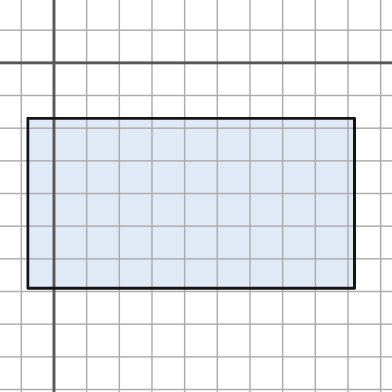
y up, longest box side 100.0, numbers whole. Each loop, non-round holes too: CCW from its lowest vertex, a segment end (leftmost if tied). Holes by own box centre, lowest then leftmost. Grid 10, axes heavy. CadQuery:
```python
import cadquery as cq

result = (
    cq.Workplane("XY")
    .moveTo(-8.0, -69.0)
    .lineTo(92.0, -69.0)
    .lineTo(92.0, -17.0)
    .lineTo(-8.0, -17.0)
    .close()
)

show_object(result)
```